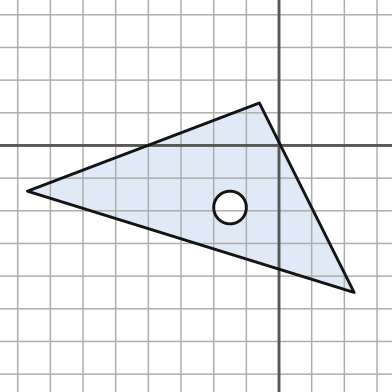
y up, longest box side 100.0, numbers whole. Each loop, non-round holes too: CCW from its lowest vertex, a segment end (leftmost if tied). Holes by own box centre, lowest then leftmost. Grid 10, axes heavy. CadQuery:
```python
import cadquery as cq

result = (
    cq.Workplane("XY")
    .moveTo(23.0, -45.0)
    .lineTo(-6.0, 13.0)
    .lineTo(-77.0, -14.0)
    .close()
    .moveTo(-15.0, -19.0)
    .circle(5.0)
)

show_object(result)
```